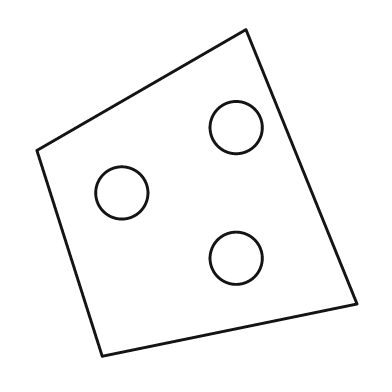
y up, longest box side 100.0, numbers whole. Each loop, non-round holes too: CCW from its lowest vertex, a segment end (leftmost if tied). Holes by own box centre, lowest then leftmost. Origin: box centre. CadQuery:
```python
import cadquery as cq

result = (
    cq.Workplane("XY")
    .moveTo(-29.0, -50.0)
    .lineTo(49.0, -34.0)
    .lineTo(15.0, 50.0)
    .lineTo(-49.0, 13.0)
    .close()
    .moveTo(12.0, -20.0)
    .circle(8.0)
    .moveTo(-23.0, 0.0)
    .circle(8.0)
    .moveTo(12.0, 20.0)
    .circle(8.0)
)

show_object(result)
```